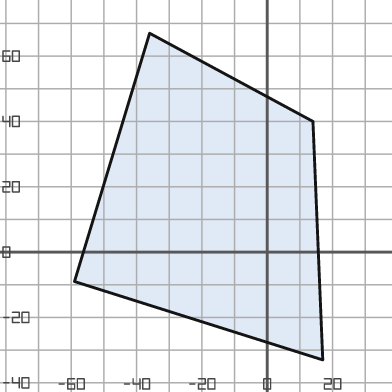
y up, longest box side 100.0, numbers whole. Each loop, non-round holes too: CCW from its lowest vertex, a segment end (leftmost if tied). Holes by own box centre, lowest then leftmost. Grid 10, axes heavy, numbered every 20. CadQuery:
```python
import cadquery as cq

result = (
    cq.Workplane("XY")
    .moveTo(17.0, -33.0)
    .lineTo(14.0, 40.0)
    .lineTo(-36.0, 67.0)
    .lineTo(-59.0, -9.0)
    .close()
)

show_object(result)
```